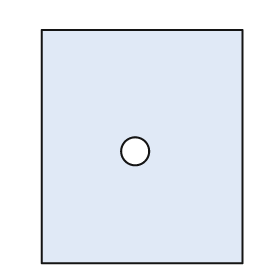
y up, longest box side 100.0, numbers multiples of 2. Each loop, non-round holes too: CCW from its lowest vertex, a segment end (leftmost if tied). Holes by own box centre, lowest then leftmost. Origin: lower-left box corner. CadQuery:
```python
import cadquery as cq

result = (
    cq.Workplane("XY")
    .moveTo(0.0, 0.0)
    .lineTo(86.0, 0.0)
    .lineTo(86.0, 100.0)
    .lineTo(0.0, 100.0)
    .close()
    .moveTo(40.0, 48.0)
    .circle(6.0)
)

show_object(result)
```